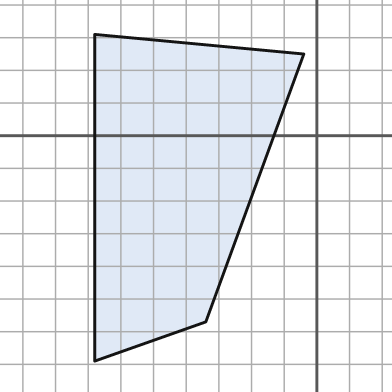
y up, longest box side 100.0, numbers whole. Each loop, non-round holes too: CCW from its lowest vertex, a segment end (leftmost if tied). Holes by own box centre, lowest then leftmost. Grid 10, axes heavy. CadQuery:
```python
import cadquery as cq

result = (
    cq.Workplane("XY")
    .moveTo(-68.0, -69.0)
    .lineTo(-34.0, -57.0)
    .lineTo(-4.0, 25.0)
    .lineTo(-68.0, 31.0)
    .close()
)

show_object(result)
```